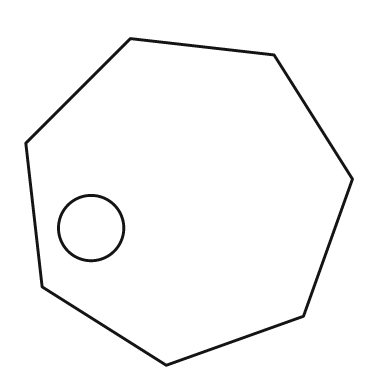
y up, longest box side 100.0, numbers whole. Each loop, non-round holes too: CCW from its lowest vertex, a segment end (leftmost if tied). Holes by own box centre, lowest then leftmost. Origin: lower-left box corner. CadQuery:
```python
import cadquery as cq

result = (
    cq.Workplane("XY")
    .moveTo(43.0, 0.0)
    .lineTo(85.0, 15.0)
    .lineTo(100.0, 57.0)
    .lineTo(76.0, 95.0)
    .lineTo(32.0, 100.0)
    .lineTo(0.0, 68.0)
    .lineTo(5.0, 24.0)
    .close()
    .moveTo(20.0, 42.0)
    .circle(10.0)
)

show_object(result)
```